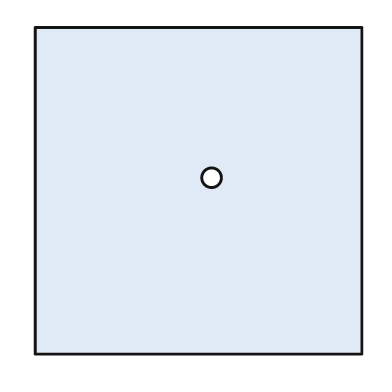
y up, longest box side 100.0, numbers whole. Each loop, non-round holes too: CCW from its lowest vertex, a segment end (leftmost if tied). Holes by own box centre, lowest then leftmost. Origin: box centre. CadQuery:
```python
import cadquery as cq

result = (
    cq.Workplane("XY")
    .moveTo(-50.0, -50.0)
    .lineTo(50.0, -50.0)
    .lineTo(50.0, 50.0)
    .lineTo(-50.0, 50.0)
    .close()
    .moveTo(4.0, 4.0)
    .circle(3.0)
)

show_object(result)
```